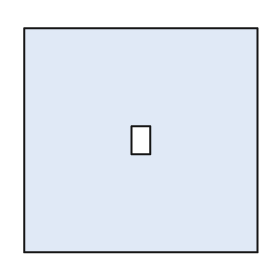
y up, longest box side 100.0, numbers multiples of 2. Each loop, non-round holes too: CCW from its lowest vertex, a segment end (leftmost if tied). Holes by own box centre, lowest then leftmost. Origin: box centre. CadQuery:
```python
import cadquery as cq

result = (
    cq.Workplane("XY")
    .moveTo(-50.0, -48.0)
    .lineTo(50.0, -48.0)
    .lineTo(50.0, 48.0)
    .lineTo(-50.0, 48.0)
    .close()
    .moveTo(-4.0, -6.0)
    .lineTo(4.0, -6.0)
    .lineTo(4.0, 6.0)
    .lineTo(-4.0, 6.0)
    .close()
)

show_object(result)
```